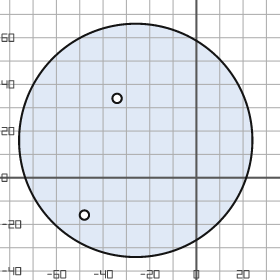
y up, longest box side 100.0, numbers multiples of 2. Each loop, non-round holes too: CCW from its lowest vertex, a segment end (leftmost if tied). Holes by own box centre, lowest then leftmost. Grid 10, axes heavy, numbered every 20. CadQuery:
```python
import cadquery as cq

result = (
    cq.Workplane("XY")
    .moveTo(-26.0, 16.0)
    .circle(50.0)
    .moveTo(-48.0, -16.0)
    .circle(2.0)
    .moveTo(-34.0, 34.0)
    .circle(2.0)
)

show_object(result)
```